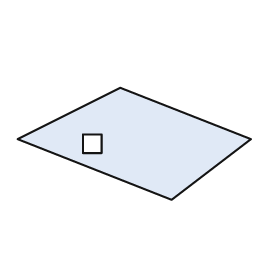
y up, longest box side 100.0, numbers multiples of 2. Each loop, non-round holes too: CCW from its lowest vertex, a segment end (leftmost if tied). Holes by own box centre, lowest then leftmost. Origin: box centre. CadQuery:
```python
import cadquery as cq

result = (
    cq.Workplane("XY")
    .moveTo(16.0, -24.0)
    .lineTo(50.0, 2.0)
    .lineTo(-6.0, 24.0)
    .lineTo(-50.0, 2.0)
    .close()
    .moveTo(-22.0, -4.0)
    .lineTo(-14.0, -4.0)
    .lineTo(-14.0, 4.0)
    .lineTo(-22.0, 4.0)
    .close()
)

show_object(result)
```